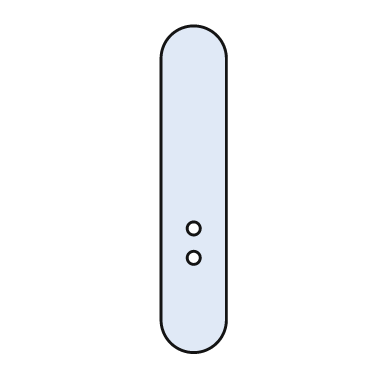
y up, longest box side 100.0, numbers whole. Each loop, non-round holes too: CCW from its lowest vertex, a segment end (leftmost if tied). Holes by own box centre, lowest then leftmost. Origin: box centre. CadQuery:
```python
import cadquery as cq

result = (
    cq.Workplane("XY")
    .moveTo(-10.0, -40.0)
    .threePointArc((0.0, -50.0), (10.0, -40.0))
    .lineTo(10.0, 40.0)
    .threePointArc((0.0, 50.0), (-10.0, 40.0))
    .close()
    .moveTo(0.0, -21.0)
    .circle(2.0)
    .moveTo(0.0, -12.0)
    .circle(2.0)
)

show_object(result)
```